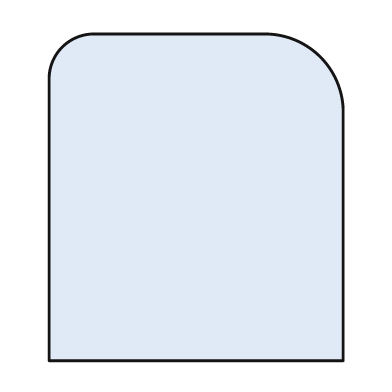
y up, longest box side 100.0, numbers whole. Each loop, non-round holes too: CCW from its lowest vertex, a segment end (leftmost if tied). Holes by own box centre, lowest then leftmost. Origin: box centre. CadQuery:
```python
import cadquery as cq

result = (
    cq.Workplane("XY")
    .moveTo(-45.0, -50.0)
    .lineTo(45.0, -50.0)
    .lineTo(45.0, 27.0)
    .threePointArc((38.0, 43.0), (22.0, 50.0))
    .lineTo(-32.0, 50.0)
    .threePointArc((-41.0, 46.0), (-45.0, 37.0))
    .close()
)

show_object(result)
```